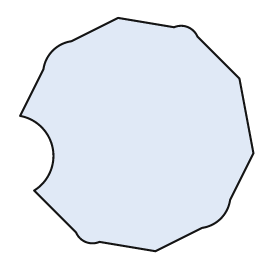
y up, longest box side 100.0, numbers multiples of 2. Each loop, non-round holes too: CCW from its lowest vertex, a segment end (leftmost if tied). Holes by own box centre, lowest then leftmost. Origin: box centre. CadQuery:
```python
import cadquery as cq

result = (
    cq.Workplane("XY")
    .moveTo(8.0, -50.0)
    .lineTo(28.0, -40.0)
    .threePointArc((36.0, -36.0), (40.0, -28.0))
    .lineTo(50.0, -8.0)
    .lineTo(44.0, 24.0)
    .lineTo(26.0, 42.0)
    .threePointArc((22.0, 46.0), (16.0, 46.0))
    .lineTo(-8.0, 50.0)
    .lineTo(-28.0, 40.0)
    .threePointArc((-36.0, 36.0), (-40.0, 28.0))
    .lineTo(-50.0, 8.0)
    .threePointArc((-36.0, -6.0), (-44.0, -24.0))
    .lineTo(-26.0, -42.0)
    .threePointArc((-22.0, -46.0), (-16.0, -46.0))
    .close()
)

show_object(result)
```